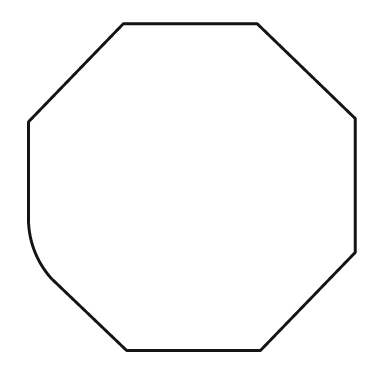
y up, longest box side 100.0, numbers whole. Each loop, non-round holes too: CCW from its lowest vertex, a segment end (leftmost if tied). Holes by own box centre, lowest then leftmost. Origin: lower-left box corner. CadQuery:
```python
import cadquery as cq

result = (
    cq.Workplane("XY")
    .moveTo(30.0, 0.0)
    .lineTo(71.0, 0.0)
    .lineTo(100.0, 30.0)
    .lineTo(100.0, 71.0)
    .lineTo(70.0, 100.0)
    .lineTo(29.0, 100.0)
    .lineTo(0.0, 70.0)
    .lineTo(0.0, 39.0)
    .threePointArc((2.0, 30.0), (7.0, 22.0))
    .close()
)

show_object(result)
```